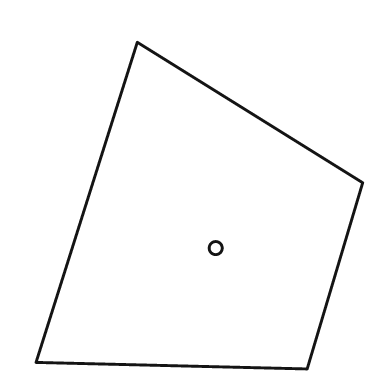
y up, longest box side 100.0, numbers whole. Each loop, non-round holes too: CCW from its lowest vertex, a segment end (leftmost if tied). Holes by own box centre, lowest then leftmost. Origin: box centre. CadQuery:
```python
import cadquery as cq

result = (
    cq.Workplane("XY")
    .moveTo(33.0, -50.0)
    .lineTo(50.0, 7.0)
    .lineTo(-19.0, 50.0)
    .lineTo(-50.0, -48.0)
    .close()
    .moveTo(5.0, -13.0)
    .circle(2.0)
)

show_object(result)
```